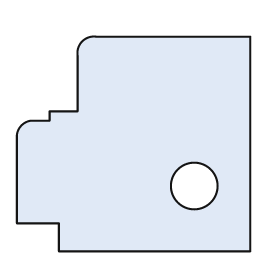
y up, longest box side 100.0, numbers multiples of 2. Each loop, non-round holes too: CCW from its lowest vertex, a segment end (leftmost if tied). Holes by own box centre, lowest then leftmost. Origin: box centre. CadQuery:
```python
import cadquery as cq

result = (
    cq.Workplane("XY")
    .moveTo(-32.0, -46.0)
    .lineTo(50.0, -46.0)
    .lineTo(50.0, 46.0)
    .lineTo(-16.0, 46.0)
    .threePointArc((-22.0, 44.0), (-24.0, 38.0))
    .lineTo(-24.0, 14.0)
    .lineTo(-36.0, 14.0)
    .lineTo(-36.0, 10.0)
    .lineTo(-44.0, 10.0)
    .threePointArc((-48.0, 8.0), (-50.0, 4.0))
    .lineTo(-50.0, -34.0)
    .lineTo(-32.0, -34.0)
    .close()
    .moveTo(26.0, -18.0)
    .circle(10.0)
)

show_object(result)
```